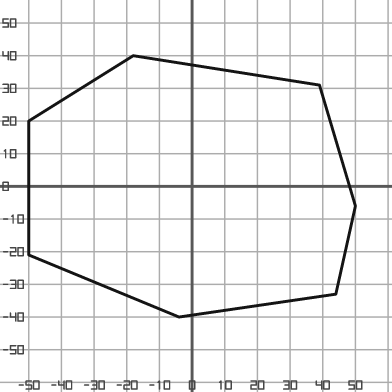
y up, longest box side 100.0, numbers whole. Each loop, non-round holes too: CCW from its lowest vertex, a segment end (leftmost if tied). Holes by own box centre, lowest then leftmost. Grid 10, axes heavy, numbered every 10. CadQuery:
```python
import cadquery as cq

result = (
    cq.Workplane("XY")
    .moveTo(-4.0, -40.0)
    .lineTo(44.0, -33.0)
    .lineTo(50.0, -6.0)
    .lineTo(39.0, 31.0)
    .lineTo(-18.0, 40.0)
    .lineTo(-50.0, 20.0)
    .lineTo(-50.0, -21.0)
    .close()
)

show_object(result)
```